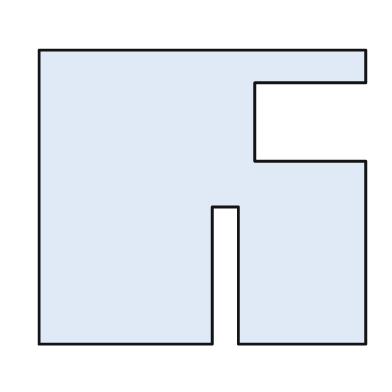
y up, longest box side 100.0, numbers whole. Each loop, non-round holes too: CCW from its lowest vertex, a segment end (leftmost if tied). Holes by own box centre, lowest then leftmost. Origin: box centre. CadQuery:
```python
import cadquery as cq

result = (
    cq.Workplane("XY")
    .moveTo(-50.0, -45.0)
    .lineTo(3.0, -45.0)
    .lineTo(3.0, -3.0)
    .lineTo(11.0, -3.0)
    .lineTo(11.0, -45.0)
    .lineTo(50.0, -45.0)
    .lineTo(50.0, 11.0)
    .lineTo(16.0, 11.0)
    .lineTo(16.0, 35.0)
    .lineTo(50.0, 35.0)
    .lineTo(50.0, 45.0)
    .lineTo(-50.0, 45.0)
    .close()
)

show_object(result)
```